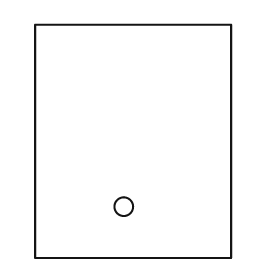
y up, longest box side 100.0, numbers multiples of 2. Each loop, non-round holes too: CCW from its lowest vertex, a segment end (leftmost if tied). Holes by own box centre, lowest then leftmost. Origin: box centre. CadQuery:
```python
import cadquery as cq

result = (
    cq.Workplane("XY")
    .moveTo(-42.0, -50.0)
    .lineTo(42.0, -50.0)
    .lineTo(42.0, 50.0)
    .lineTo(-42.0, 50.0)
    .close()
    .moveTo(-4.0, -28.0)
    .circle(4.0)
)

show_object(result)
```